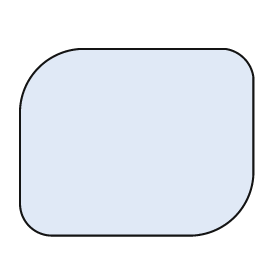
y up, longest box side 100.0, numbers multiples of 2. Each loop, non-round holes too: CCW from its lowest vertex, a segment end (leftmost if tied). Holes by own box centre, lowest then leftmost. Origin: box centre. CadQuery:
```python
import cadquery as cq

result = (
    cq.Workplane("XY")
    .moveTo(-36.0, -40.0)
    .lineTo(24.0, -40.0)
    .threePointArc((42.0, -32.0), (50.0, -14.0))
    .lineTo(50.0, 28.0)
    .threePointArc((46.0, 36.0), (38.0, 40.0))
    .lineTo(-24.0, 40.0)
    .threePointArc((-42.0, 32.0), (-50.0, 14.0))
    .lineTo(-50.0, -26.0)
    .threePointArc((-46.0, -36.0), (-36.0, -40.0))
    .close()
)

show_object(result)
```